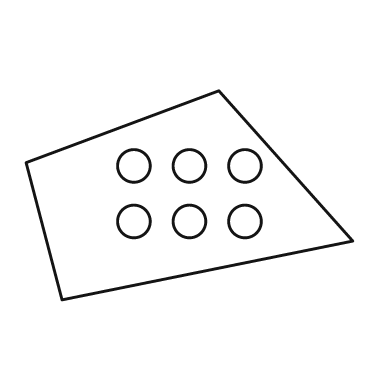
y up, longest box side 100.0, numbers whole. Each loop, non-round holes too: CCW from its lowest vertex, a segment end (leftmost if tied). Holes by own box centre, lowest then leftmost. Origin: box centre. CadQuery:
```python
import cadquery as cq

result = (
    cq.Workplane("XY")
    .moveTo(-39.0, -32.0)
    .lineTo(50.0, -14.0)
    .lineTo(9.0, 32.0)
    .lineTo(-50.0, 10.0)
    .close()
    .moveTo(-17.0, -8.0)
    .circle(5.0)
    .moveTo(0.0, -8.0)
    .circle(5.0)
    .moveTo(17.0, -8.0)
    .circle(5.0)
    .moveTo(-17.0, 9.0)
    .circle(5.0)
    .moveTo(0.0, 9.0)
    .circle(5.0)
    .moveTo(17.0, 9.0)
    .circle(5.0)
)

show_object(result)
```